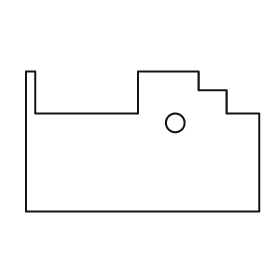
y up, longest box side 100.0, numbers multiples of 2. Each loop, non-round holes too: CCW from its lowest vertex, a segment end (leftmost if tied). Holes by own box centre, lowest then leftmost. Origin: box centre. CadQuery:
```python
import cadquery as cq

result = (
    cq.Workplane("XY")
    .moveTo(-50.0, -30.0)
    .lineTo(50.0, -30.0)
    .lineTo(50.0, 12.0)
    .lineTo(36.0, 12.0)
    .lineTo(36.0, 22.0)
    .lineTo(24.0, 22.0)
    .lineTo(24.0, 30.0)
    .lineTo(-2.0, 30.0)
    .lineTo(-2.0, 12.0)
    .lineTo(-46.0, 12.0)
    .lineTo(-46.0, 30.0)
    .lineTo(-50.0, 30.0)
    .close()
    .moveTo(14.0, 8.0)
    .circle(4.0)
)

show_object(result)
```